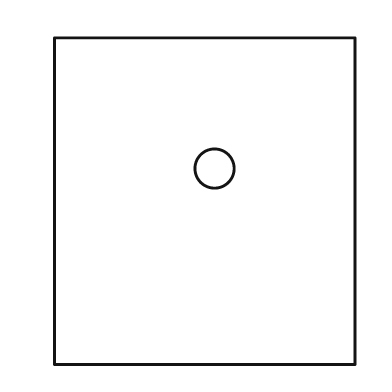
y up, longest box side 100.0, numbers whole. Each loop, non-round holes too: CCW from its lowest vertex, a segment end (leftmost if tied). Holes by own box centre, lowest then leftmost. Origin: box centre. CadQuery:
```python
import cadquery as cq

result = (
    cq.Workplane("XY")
    .moveTo(-46.0, -50.0)
    .lineTo(46.0, -50.0)
    .lineTo(46.0, 50.0)
    .lineTo(-46.0, 50.0)
    .close()
    .moveTo(3.0, 10.0)
    .circle(6.0)
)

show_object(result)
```